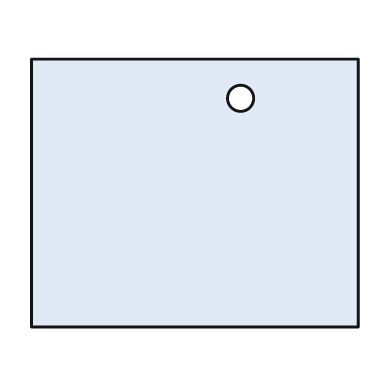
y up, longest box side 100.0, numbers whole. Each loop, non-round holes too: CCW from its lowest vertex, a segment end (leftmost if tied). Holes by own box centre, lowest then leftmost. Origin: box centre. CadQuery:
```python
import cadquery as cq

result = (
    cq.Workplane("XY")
    .moveTo(-50.0, -41.0)
    .lineTo(50.0, -41.0)
    .lineTo(50.0, 41.0)
    .lineTo(-50.0, 41.0)
    .close()
    .moveTo(14.0, 29.0)
    .circle(4.0)
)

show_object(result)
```